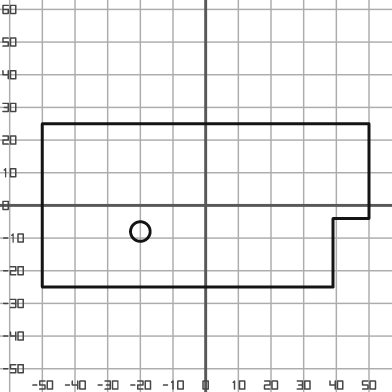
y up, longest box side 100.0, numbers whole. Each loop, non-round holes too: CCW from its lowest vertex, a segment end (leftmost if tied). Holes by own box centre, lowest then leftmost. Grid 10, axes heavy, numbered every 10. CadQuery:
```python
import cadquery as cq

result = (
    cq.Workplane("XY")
    .moveTo(-50.0, -25.0)
    .lineTo(39.0, -25.0)
    .lineTo(39.0, -4.0)
    .lineTo(50.0, -4.0)
    .lineTo(50.0, 25.0)
    .lineTo(-50.0, 25.0)
    .close()
    .moveTo(-20.0, -8.0)
    .circle(3.0)
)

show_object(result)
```